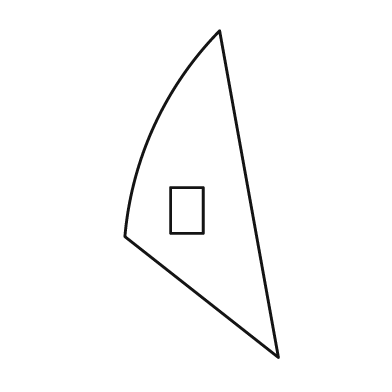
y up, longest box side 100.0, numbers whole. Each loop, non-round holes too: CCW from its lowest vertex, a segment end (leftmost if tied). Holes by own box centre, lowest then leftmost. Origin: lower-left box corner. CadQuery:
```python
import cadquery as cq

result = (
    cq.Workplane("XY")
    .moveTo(47.0, 0.0)
    .lineTo(29.0, 100.0)
    .threePointArc((9.0, 71.0), (0.0, 37.0))
    .close()
    .moveTo(14.0, 38.0)
    .lineTo(24.0, 38.0)
    .lineTo(24.0, 52.0)
    .lineTo(14.0, 52.0)
    .close()
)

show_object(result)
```